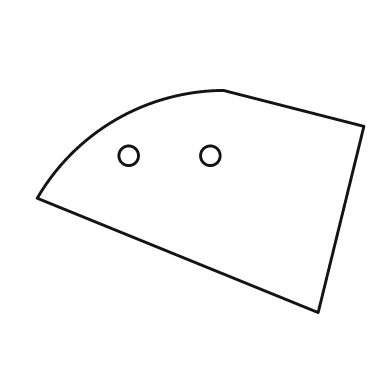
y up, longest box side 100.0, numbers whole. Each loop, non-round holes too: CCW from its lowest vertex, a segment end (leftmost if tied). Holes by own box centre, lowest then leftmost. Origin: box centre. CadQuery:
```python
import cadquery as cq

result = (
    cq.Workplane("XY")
    .moveTo(36.0, -34.0)
    .lineTo(50.0, 23.0)
    .lineTo(7.0, 34.0)
    .threePointArc((-26.0, 25.0), (-50.0, 1.0))
    .close()
    .moveTo(-22.0, 14.0)
    .circle(3.0)
    .moveTo(3.0, 14.0)
    .circle(3.0)
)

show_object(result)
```